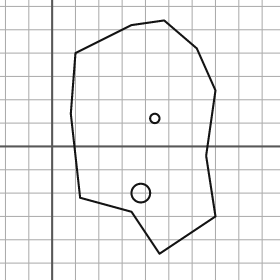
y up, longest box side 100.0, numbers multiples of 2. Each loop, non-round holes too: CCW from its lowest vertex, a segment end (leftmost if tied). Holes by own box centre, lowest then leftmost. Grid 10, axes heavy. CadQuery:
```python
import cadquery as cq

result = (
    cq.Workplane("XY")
    .moveTo(46.0, -46.0)
    .lineTo(70.0, -30.0)
    .lineTo(66.0, -4.0)
    .lineTo(70.0, 24.0)
    .lineTo(62.0, 42.0)
    .lineTo(48.0, 54.0)
    .lineTo(34.0, 52.0)
    .lineTo(10.0, 40.0)
    .lineTo(8.0, 14.0)
    .lineTo(12.0, -22.0)
    .lineTo(34.0, -28.0)
    .close()
    .moveTo(38.0, -20.0)
    .circle(4.0)
    .moveTo(44.0, 12.0)
    .circle(2.0)
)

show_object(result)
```